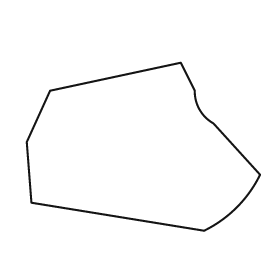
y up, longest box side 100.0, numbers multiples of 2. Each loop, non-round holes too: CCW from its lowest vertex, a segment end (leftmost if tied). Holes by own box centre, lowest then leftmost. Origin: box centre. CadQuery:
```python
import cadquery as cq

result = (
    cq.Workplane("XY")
    .moveTo(26.0, -36.0)
    .threePointArc((40.0, -26.0), (50.0, -12.0))
    .lineTo(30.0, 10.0)
    .threePointArc((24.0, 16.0), (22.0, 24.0))
    .lineTo(16.0, 36.0)
    .lineTo(-40.0, 24.0)
    .lineTo(-50.0, 2.0)
    .lineTo(-48.0, -24.0)
    .close()
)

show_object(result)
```